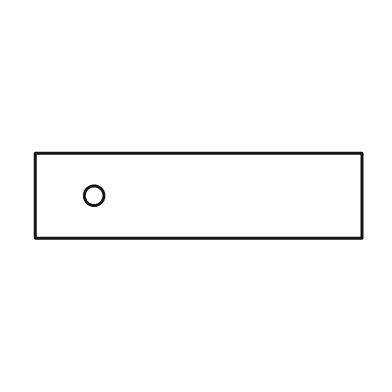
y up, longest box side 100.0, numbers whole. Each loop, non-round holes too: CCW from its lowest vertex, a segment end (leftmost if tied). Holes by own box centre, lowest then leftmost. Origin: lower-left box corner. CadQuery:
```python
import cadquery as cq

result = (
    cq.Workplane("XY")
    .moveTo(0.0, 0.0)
    .lineTo(100.0, 0.0)
    .lineTo(100.0, 26.0)
    .lineTo(0.0, 26.0)
    .close()
    .moveTo(18.0, 13.0)
    .circle(3.0)
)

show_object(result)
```